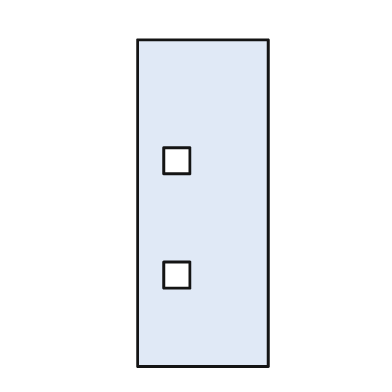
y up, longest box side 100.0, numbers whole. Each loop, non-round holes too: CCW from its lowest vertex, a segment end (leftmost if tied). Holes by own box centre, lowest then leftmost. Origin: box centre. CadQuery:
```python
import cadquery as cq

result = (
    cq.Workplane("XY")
    .moveTo(-20.0, -50.0)
    .lineTo(20.0, -50.0)
    .lineTo(20.0, 50.0)
    .lineTo(-20.0, 50.0)
    .close()
    .moveTo(-12.0, -26.0)
    .lineTo(-4.0, -26.0)
    .lineTo(-4.0, -18.0)
    .lineTo(-12.0, -18.0)
    .close()
    .moveTo(-12.0, 9.0)
    .lineTo(-4.0, 9.0)
    .lineTo(-4.0, 17.0)
    .lineTo(-12.0, 17.0)
    .close()
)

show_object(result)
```